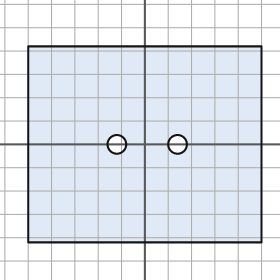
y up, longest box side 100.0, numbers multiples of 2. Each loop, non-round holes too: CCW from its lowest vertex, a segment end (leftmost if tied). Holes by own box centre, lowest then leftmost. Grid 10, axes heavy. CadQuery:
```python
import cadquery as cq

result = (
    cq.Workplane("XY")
    .moveTo(-50.0, -42.0)
    .lineTo(50.0, -42.0)
    .lineTo(50.0, 42.0)
    .lineTo(-50.0, 42.0)
    .close()
    .moveTo(-12.0, 0.0)
    .circle(4.0)
    .moveTo(14.0, 0.0)
    .circle(4.0)
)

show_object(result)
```